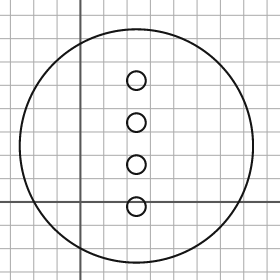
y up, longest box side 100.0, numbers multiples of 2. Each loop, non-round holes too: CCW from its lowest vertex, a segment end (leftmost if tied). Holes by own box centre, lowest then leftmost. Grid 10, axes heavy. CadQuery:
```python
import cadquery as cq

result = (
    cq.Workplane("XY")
    .moveTo(24.0, 24.0)
    .circle(50.0)
    .moveTo(24.0, -2.0)
    .circle(4.0)
    .moveTo(24.0, 16.0)
    .circle(4.0)
    .moveTo(24.0, 34.0)
    .circle(4.0)
    .moveTo(24.0, 52.0)
    .circle(4.0)
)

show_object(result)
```